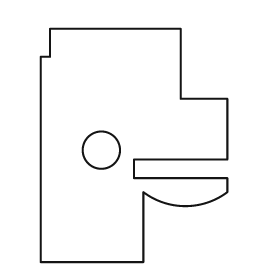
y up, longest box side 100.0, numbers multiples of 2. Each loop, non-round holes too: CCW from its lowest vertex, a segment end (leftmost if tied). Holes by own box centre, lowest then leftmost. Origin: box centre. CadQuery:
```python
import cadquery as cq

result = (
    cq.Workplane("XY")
    .moveTo(-40.0, -50.0)
    .lineTo(4.0, -50.0)
    .lineTo(4.0, -20.0)
    .threePointArc((22.0, -26.0), (40.0, -20.0))
    .lineTo(40.0, -14.0)
    .lineTo(0.0, -14.0)
    .lineTo(0.0, -6.0)
    .lineTo(40.0, -6.0)
    .lineTo(40.0, 20.0)
    .lineTo(20.0, 20.0)
    .lineTo(20.0, 50.0)
    .lineTo(-36.0, 50.0)
    .lineTo(-36.0, 38.0)
    .lineTo(-40.0, 38.0)
    .close()
    .moveTo(-14.0, -2.0)
    .circle(8.0)
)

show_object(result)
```